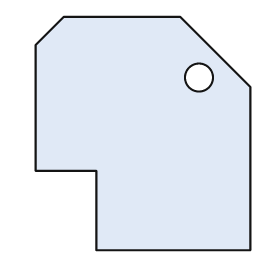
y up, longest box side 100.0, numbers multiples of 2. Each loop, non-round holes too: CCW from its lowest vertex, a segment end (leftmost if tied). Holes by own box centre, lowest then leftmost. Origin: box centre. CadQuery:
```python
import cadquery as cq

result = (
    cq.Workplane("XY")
    .moveTo(-20.0, -50.0)
    .lineTo(46.0, -50.0)
    .lineTo(46.0, 20.0)
    .lineTo(16.0, 50.0)
    .lineTo(-34.0, 50.0)
    .lineTo(-46.0, 38.0)
    .lineTo(-46.0, -16.0)
    .lineTo(-20.0, -16.0)
    .close()
    .moveTo(24.0, 24.0)
    .circle(6.0)
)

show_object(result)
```